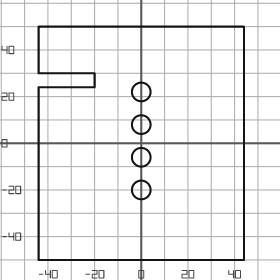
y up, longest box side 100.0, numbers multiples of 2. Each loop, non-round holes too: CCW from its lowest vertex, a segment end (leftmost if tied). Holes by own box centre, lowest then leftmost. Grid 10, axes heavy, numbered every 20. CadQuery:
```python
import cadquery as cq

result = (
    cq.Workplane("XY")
    .moveTo(-44.0, -50.0)
    .lineTo(44.0, -50.0)
    .lineTo(44.0, 50.0)
    .lineTo(-44.0, 50.0)
    .lineTo(-44.0, 30.0)
    .lineTo(-20.0, 30.0)
    .lineTo(-20.0, 24.0)
    .lineTo(-44.0, 24.0)
    .close()
    .moveTo(0.0, -20.0)
    .circle(4.0)
    .moveTo(0.0, -6.0)
    .circle(4.0)
    .moveTo(0.0, 8.0)
    .circle(4.0)
    .moveTo(0.0, 22.0)
    .circle(4.0)
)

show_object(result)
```